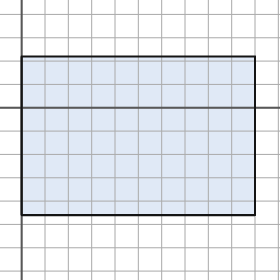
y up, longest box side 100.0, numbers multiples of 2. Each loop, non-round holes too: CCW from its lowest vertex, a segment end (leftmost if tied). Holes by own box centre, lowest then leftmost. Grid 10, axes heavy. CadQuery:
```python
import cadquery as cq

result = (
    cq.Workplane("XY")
    .moveTo(0.0, -46.0)
    .lineTo(100.0, -46.0)
    .lineTo(100.0, 22.0)
    .lineTo(0.0, 22.0)
    .close()
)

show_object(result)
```